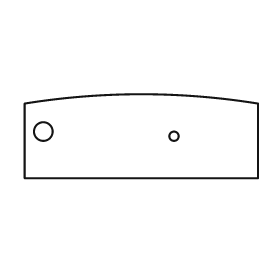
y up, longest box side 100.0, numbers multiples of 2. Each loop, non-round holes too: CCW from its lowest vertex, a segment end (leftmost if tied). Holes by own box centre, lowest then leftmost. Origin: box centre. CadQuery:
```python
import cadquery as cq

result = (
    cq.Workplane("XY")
    .moveTo(-50.0, -18.0)
    .lineTo(50.0, -18.0)
    .lineTo(50.0, 14.0)
    .threePointArc((0.0, 18.0), (-50.0, 14.0))
    .close()
    .moveTo(14.0, 0.0)
    .circle(2.0)
    .moveTo(-42.0, 2.0)
    .circle(4.0)
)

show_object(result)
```